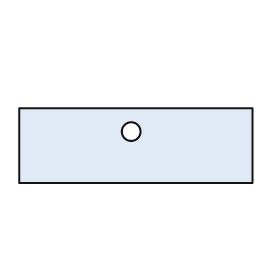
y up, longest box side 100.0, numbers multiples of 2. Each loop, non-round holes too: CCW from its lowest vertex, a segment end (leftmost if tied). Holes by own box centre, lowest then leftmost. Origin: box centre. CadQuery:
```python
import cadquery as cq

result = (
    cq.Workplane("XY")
    .moveTo(-50.0, -16.0)
    .lineTo(50.0, -16.0)
    .lineTo(50.0, 16.0)
    .lineTo(-50.0, 16.0)
    .close()
    .moveTo(-2.0, 6.0)
    .circle(4.0)
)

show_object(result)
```